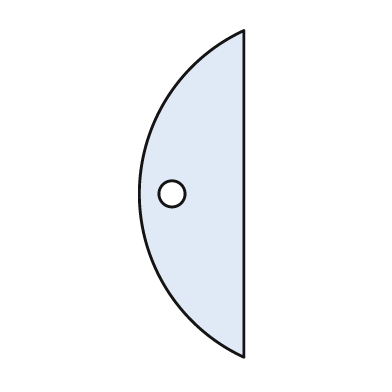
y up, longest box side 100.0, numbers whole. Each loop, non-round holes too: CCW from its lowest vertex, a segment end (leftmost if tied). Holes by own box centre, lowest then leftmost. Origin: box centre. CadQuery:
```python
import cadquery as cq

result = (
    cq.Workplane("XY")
    .moveTo(16.0, -50.0)
    .lineTo(16.0, 50.0)
    .threePointArc((-16.0, 0.0), (16.0, -50.0))
    .close()
    .moveTo(-6.0, 0.0)
    .circle(4.0)
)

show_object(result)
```